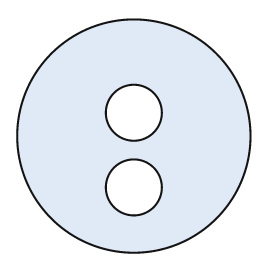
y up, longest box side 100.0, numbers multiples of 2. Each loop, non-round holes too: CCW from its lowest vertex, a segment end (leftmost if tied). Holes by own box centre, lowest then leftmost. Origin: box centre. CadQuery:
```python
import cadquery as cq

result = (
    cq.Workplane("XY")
    .moveTo(0.0, 0.0)
    .circle(50.0)
    .moveTo(0.0, -22.0)
    .circle(12.0)
    .moveTo(0.0, 10.0)
    .circle(12.0)
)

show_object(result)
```